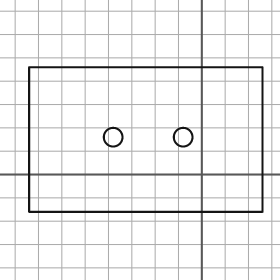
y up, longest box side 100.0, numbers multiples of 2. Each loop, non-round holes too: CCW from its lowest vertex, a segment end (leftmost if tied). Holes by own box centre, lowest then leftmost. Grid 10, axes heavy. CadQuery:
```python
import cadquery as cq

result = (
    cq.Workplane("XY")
    .moveTo(-74.0, -16.0)
    .lineTo(26.0, -16.0)
    .lineTo(26.0, 46.0)
    .lineTo(-74.0, 46.0)
    .close()
    .moveTo(-38.0, 16.0)
    .circle(4.0)
    .moveTo(-8.0, 16.0)
    .circle(4.0)
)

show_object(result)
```